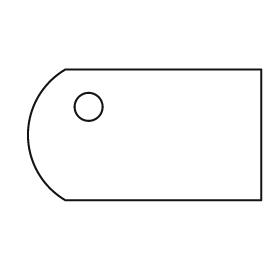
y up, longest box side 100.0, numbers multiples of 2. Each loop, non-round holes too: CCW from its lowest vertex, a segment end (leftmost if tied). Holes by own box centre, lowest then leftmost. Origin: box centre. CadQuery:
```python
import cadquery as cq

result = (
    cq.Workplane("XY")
    .moveTo(-34.0, -28.0)
    .lineTo(50.0, -28.0)
    .lineTo(50.0, 28.0)
    .lineTo(-34.0, 28.0)
    .threePointArc((-50.0, 0.0), (-34.0, -28.0))
    .close()
    .moveTo(-24.0, 12.0)
    .circle(6.0)
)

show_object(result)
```